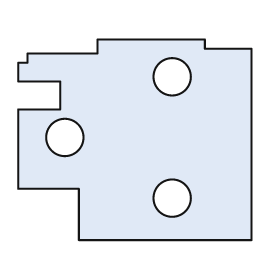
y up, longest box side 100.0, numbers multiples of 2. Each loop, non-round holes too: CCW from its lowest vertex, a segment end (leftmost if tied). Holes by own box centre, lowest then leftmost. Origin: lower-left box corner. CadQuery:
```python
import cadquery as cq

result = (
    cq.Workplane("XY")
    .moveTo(26.0, 0.0)
    .lineTo(100.0, 0.0)
    .lineTo(100.0, 82.0)
    .lineTo(80.0, 82.0)
    .lineTo(80.0, 86.0)
    .lineTo(34.0, 86.0)
    .lineTo(34.0, 80.0)
    .lineTo(4.0, 80.0)
    .lineTo(4.0, 76.0)
    .lineTo(0.0, 76.0)
    .lineTo(0.0, 68.0)
    .lineTo(18.0, 68.0)
    .lineTo(18.0, 56.0)
    .lineTo(0.0, 56.0)
    .lineTo(0.0, 22.0)
    .lineTo(26.0, 22.0)
    .close()
    .moveTo(66.0, 18.0)
    .circle(8.0)
    .moveTo(20.0, 44.0)
    .circle(8.0)
    .moveTo(66.0, 70.0)
    .circle(8.0)
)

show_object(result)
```